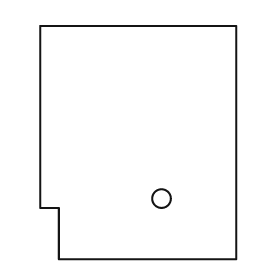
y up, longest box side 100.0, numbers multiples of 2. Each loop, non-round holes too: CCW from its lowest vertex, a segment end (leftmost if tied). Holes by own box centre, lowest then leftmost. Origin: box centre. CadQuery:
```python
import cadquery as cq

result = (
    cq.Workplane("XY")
    .moveTo(-34.0, -50.0)
    .lineTo(42.0, -50.0)
    .lineTo(42.0, 50.0)
    .lineTo(-42.0, 50.0)
    .lineTo(-42.0, -28.0)
    .lineTo(-34.0, -28.0)
    .close()
    .moveTo(10.0, -24.0)
    .circle(4.0)
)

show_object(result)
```